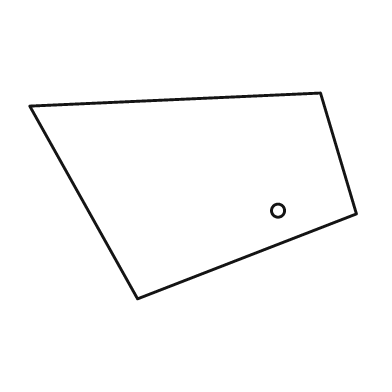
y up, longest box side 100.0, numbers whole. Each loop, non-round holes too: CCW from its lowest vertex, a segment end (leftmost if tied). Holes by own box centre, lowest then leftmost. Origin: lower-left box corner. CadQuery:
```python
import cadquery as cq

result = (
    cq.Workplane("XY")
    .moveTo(33.0, 0.0)
    .lineTo(100.0, 26.0)
    .lineTo(89.0, 63.0)
    .lineTo(0.0, 59.0)
    .close()
    .moveTo(76.0, 27.0)
    .circle(2.0)
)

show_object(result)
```